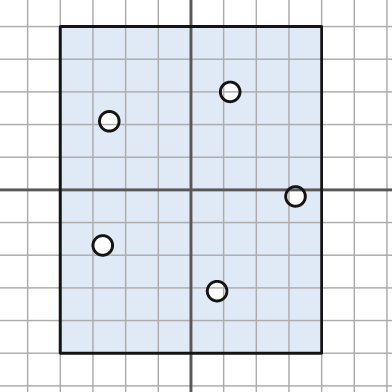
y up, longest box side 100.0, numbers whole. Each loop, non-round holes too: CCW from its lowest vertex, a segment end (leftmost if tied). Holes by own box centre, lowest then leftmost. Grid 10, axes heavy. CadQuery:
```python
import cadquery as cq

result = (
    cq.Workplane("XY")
    .moveTo(-40.0, -50.0)
    .lineTo(40.0, -50.0)
    .lineTo(40.0, 50.0)
    .lineTo(-40.0, 50.0)
    .close()
    .moveTo(8.0, -31.0)
    .circle(3.0)
    .moveTo(-27.0, -17.0)
    .circle(3.0)
    .moveTo(32.0, -2.0)
    .circle(3.0)
    .moveTo(-25.0, 21.0)
    .circle(3.0)
    .moveTo(12.0, 30.0)
    .circle(3.0)
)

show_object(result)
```